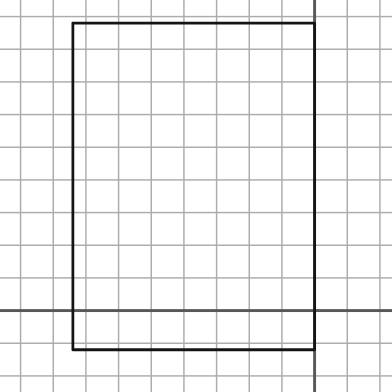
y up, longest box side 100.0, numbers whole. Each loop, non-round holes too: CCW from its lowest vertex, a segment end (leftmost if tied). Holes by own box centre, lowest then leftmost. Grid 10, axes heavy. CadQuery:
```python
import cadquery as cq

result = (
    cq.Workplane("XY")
    .moveTo(-74.0, -12.0)
    .lineTo(0.0, -12.0)
    .lineTo(0.0, 88.0)
    .lineTo(-74.0, 88.0)
    .close()
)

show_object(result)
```